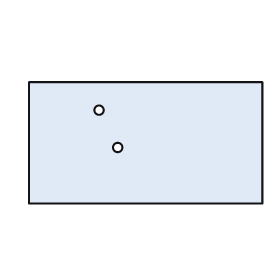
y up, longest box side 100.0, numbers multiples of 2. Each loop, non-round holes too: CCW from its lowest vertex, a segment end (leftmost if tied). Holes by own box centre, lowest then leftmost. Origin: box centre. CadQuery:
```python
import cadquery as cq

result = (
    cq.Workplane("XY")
    .moveTo(-50.0, -26.0)
    .lineTo(50.0, -26.0)
    .lineTo(50.0, 26.0)
    .lineTo(-50.0, 26.0)
    .close()
    .moveTo(-12.0, -2.0)
    .circle(2.0)
    .moveTo(-20.0, 14.0)
    .circle(2.0)
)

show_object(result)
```